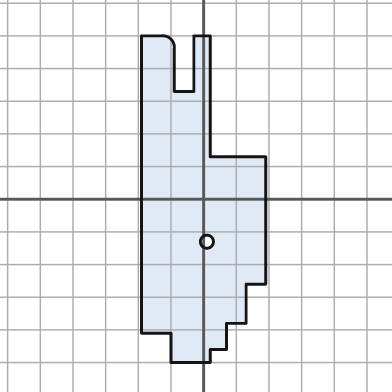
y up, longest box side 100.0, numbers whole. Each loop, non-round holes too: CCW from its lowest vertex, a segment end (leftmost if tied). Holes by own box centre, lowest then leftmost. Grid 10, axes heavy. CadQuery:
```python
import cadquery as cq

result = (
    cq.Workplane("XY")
    .moveTo(-10.0, -50.0)
    .lineTo(2.0, -50.0)
    .lineTo(2.0, -46.0)
    .lineTo(7.0, -46.0)
    .lineTo(7.0, -38.0)
    .lineTo(13.0, -38.0)
    .lineTo(13.0, -26.0)
    .lineTo(19.0, -26.0)
    .lineTo(19.0, 13.0)
    .lineTo(2.0, 13.0)
    .lineTo(2.0, 50.0)
    .lineTo(-3.0, 50.0)
    .lineTo(-3.0, 33.0)
    .lineTo(-9.0, 33.0)
    .lineTo(-9.0, 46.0)
    .threePointArc((-10.0, 49.0), (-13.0, 50.0))
    .lineTo(-19.0, 50.0)
    .lineTo(-19.0, -41.0)
    .lineTo(-10.0, -41.0)
    .close()
    .moveTo(1.0, -13.0)
    .circle(2.0)
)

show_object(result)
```